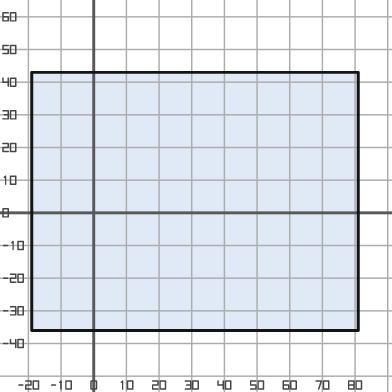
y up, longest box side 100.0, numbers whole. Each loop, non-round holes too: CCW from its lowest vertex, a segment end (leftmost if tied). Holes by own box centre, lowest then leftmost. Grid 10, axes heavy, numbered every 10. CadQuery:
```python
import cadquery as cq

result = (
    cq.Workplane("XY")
    .moveTo(-19.0, -36.0)
    .lineTo(81.0, -36.0)
    .lineTo(81.0, 43.0)
    .lineTo(-19.0, 43.0)
    .close()
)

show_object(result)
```